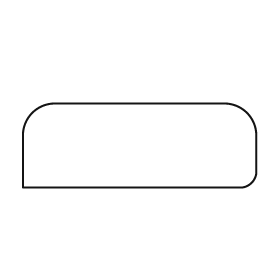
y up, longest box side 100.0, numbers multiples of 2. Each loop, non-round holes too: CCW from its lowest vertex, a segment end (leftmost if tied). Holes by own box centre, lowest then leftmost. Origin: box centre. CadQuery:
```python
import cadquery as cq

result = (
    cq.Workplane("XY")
    .moveTo(-50.0, -18.0)
    .lineTo(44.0, -18.0)
    .threePointArc((48.0, -16.0), (50.0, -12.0))
    .lineTo(50.0, 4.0)
    .threePointArc((46.0, 14.0), (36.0, 18.0))
    .lineTo(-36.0, 18.0)
    .threePointArc((-46.0, 14.0), (-50.0, 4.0))
    .close()
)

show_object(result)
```